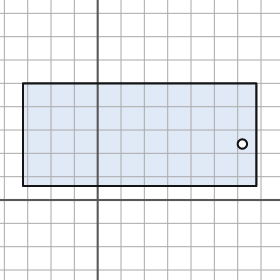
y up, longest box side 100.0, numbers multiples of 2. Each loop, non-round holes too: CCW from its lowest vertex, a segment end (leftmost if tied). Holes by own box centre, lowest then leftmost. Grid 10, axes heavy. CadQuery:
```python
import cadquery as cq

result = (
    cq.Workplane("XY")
    .moveTo(-32.0, 6.0)
    .lineTo(68.0, 6.0)
    .lineTo(68.0, 50.0)
    .lineTo(-32.0, 50.0)
    .close()
    .moveTo(62.0, 24.0)
    .circle(2.0)
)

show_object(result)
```